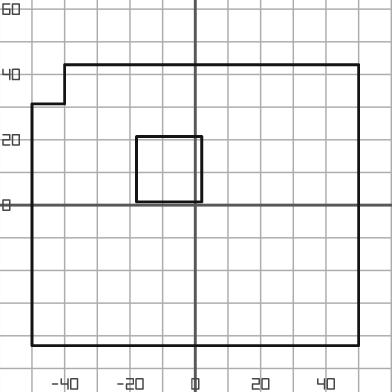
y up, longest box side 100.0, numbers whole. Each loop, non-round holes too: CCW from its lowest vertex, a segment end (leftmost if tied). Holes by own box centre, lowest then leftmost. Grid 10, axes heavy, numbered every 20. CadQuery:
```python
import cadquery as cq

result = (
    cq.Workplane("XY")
    .moveTo(-50.0, -43.0)
    .lineTo(50.0, -43.0)
    .lineTo(50.0, 43.0)
    .lineTo(-40.0, 43.0)
    .lineTo(-40.0, 31.0)
    .lineTo(-50.0, 31.0)
    .close()
    .moveTo(-18.0, 1.0)
    .lineTo(2.0, 1.0)
    .lineTo(2.0, 21.0)
    .lineTo(-18.0, 21.0)
    .close()
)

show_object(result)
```